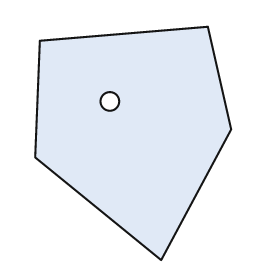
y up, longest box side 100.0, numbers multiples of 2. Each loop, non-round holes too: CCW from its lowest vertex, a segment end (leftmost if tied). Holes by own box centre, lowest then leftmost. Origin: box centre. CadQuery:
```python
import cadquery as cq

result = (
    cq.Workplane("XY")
    .moveTo(12.0, -50.0)
    .lineTo(42.0, 6.0)
    .lineTo(32.0, 50.0)
    .lineTo(-40.0, 44.0)
    .lineTo(-42.0, -6.0)
    .close()
    .moveTo(-10.0, 18.0)
    .circle(4.0)
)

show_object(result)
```